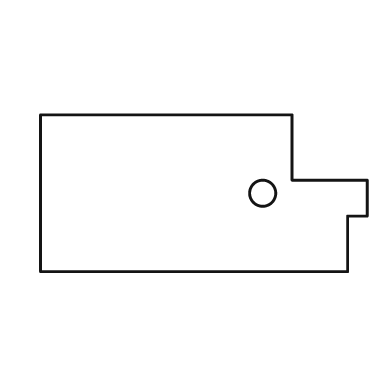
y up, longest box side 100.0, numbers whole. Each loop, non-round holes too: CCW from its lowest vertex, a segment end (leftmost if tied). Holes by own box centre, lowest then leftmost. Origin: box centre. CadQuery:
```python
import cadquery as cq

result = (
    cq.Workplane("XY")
    .moveTo(-50.0, -24.0)
    .lineTo(44.0, -24.0)
    .lineTo(44.0, -7.0)
    .lineTo(50.0, -7.0)
    .lineTo(50.0, 4.0)
    .lineTo(27.0, 4.0)
    .lineTo(27.0, 24.0)
    .lineTo(-50.0, 24.0)
    .close()
    .moveTo(18.0, 0.0)
    .circle(4.0)
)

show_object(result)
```